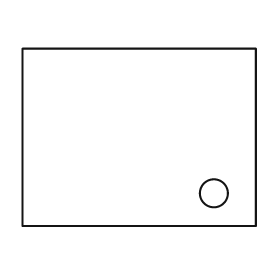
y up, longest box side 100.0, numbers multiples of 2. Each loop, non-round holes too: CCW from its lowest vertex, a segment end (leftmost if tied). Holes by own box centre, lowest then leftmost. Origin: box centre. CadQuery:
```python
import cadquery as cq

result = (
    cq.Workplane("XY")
    .moveTo(-50.0, -38.0)
    .lineTo(50.0, -38.0)
    .lineTo(50.0, 38.0)
    .lineTo(-50.0, 38.0)
    .close()
    .moveTo(32.0, -24.0)
    .circle(6.0)
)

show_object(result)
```